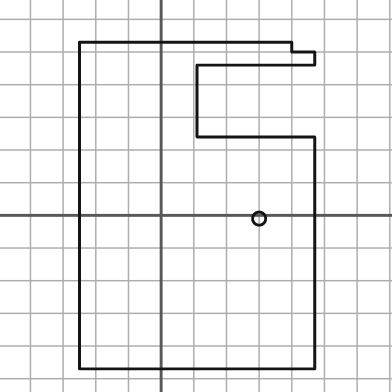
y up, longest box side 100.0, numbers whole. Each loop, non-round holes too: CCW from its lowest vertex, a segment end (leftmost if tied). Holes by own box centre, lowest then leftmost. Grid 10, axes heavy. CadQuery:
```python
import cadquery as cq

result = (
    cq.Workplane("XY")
    .moveTo(-25.0, -47.0)
    .lineTo(47.0, -47.0)
    .lineTo(47.0, 24.0)
    .lineTo(11.0, 24.0)
    .lineTo(11.0, 46.0)
    .lineTo(47.0, 46.0)
    .lineTo(47.0, 50.0)
    .lineTo(40.0, 50.0)
    .lineTo(40.0, 53.0)
    .lineTo(-25.0, 53.0)
    .close()
    .moveTo(30.0, -1.0)
    .circle(2.0)
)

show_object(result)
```